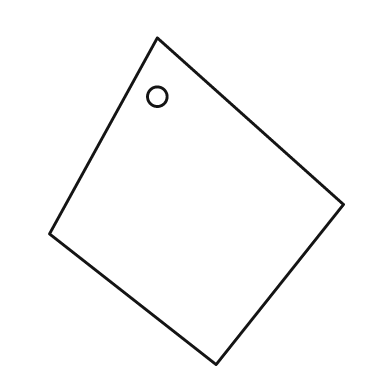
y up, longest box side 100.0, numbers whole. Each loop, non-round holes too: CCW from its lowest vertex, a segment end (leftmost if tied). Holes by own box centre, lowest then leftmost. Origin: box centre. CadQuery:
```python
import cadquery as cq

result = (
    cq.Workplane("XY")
    .moveTo(6.0, -50.0)
    .lineTo(45.0, -1.0)
    .lineTo(-12.0, 50.0)
    .lineTo(-45.0, -10.0)
    .close()
    .moveTo(-12.0, 32.0)
    .circle(3.0)
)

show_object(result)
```